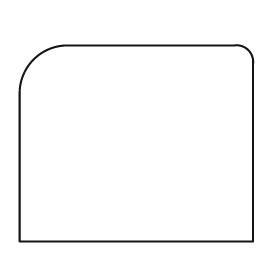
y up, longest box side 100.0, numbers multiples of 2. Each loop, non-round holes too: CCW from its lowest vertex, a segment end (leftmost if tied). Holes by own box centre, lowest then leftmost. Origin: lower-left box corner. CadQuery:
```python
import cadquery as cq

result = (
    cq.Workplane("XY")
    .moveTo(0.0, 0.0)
    .lineTo(100.0, 0.0)
    .lineTo(100.0, 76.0)
    .threePointArc((98.0, 82.0), (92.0, 84.0))
    .lineTo(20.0, 84.0)
    .threePointArc((6.0, 78.0), (0.0, 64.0))
    .close()
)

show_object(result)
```